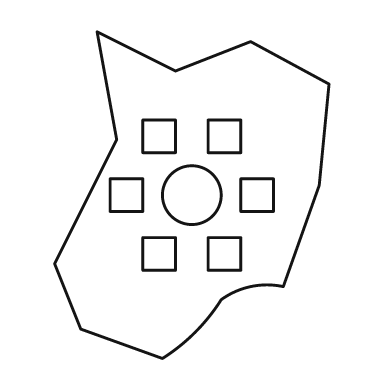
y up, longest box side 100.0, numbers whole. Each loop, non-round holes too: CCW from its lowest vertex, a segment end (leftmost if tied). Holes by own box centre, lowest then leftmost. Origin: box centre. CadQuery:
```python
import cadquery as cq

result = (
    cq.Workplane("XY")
    .moveTo(-9.0, -50.0)
    .threePointArc((1.0, -42.0), (9.0, -32.0))
    .threePointArc((18.0, -28.0), (28.0, -28.0))
    .lineTo(39.0, 3.0)
    .lineTo(42.0, 34.0)
    .lineTo(18.0, 47.0)
    .lineTo(-5.0, 38.0)
    .lineTo(-29.0, 50.0)
    .lineTo(-23.0, 17.0)
    .lineTo(-42.0, -21.0)
    .lineTo(-34.0, -41.0)
    .close()
    .moveTo(-15.0, -23.0)
    .lineTo(-5.0, -23.0)
    .lineTo(-5.0, -13.0)
    .lineTo(-15.0, -13.0)
    .close()
    .moveTo(5.0, -23.0)
    .lineTo(15.0, -23.0)
    .lineTo(15.0, -13.0)
    .lineTo(5.0, -13.0)
    .close()
    .moveTo(-25.0, -5.0)
    .lineTo(-15.0, -5.0)
    .lineTo(-15.0, 5.0)
    .lineTo(-25.0, 5.0)
    .close()
    .moveTo(0.0, 0.0)
    .circle(9.0)
    .moveTo(15.0, -5.0)
    .lineTo(25.0, -5.0)
    .lineTo(25.0, 5.0)
    .lineTo(15.0, 5.0)
    .close()
    .moveTo(-15.0, 13.0)
    .lineTo(-5.0, 13.0)
    .lineTo(-5.0, 23.0)
    .lineTo(-15.0, 23.0)
    .close()
    .moveTo(5.0, 13.0)
    .lineTo(15.0, 13.0)
    .lineTo(15.0, 23.0)
    .lineTo(5.0, 23.0)
    .close()
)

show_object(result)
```